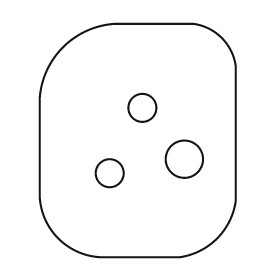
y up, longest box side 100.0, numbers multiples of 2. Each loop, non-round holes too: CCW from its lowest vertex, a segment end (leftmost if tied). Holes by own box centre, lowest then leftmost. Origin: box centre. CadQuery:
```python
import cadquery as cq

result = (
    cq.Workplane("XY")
    .moveTo(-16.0, -50.0)
    .lineTo(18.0, -50.0)
    .threePointArc((34.0, -42.0), (42.0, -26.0))
    .lineTo(42.0, 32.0)
    .threePointArc((36.0, 44.0), (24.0, 50.0))
    .lineTo(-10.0, 50.0)
    .threePointArc((-32.0, 40.0), (-42.0, 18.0))
    .lineTo(-42.0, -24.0)
    .threePointArc((-34.0, -42.0), (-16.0, -50.0))
    .close()
    .moveTo(-12.0, -14.0)
    .circle(6.0)
    .moveTo(20.0, -8.0)
    .circle(8.0)
    .moveTo(2.0, 14.0)
    .circle(6.0)
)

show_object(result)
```